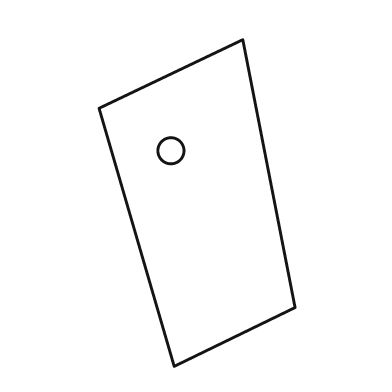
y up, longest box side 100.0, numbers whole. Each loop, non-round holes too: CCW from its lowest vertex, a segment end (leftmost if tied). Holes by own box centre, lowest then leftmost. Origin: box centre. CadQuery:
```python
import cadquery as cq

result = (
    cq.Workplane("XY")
    .moveTo(-7.0, -50.0)
    .lineTo(30.0, -32.0)
    .lineTo(14.0, 50.0)
    .lineTo(-30.0, 29.0)
    .close()
    .moveTo(-8.0, 16.0)
    .circle(4.0)
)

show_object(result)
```